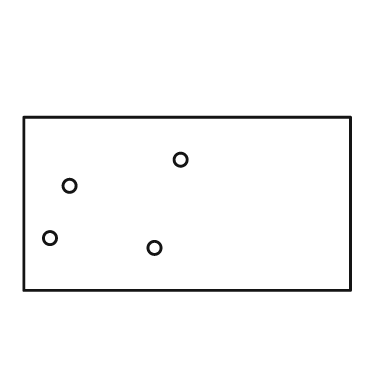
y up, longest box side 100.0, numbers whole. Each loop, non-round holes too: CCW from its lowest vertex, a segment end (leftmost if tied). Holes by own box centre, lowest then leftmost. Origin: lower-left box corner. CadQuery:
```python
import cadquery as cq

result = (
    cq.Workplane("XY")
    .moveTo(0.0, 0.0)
    .lineTo(100.0, 0.0)
    .lineTo(100.0, 53.0)
    .lineTo(0.0, 53.0)
    .close()
    .moveTo(40.0, 13.0)
    .circle(2.0)
    .moveTo(8.0, 16.0)
    .circle(2.0)
    .moveTo(14.0, 32.0)
    .circle(2.0)
    .moveTo(48.0, 40.0)
    .circle(2.0)
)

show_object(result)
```